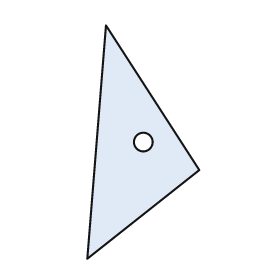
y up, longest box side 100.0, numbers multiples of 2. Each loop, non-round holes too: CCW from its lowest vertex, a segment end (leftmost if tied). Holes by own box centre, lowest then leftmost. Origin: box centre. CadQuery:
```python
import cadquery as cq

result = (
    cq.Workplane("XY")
    .moveTo(-24.0, -50.0)
    .lineTo(24.0, -12.0)
    .lineTo(-16.0, 50.0)
    .close()
    .moveTo(0.0, 0.0)
    .circle(4.0)
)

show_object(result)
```